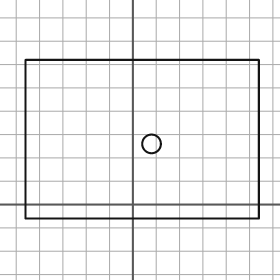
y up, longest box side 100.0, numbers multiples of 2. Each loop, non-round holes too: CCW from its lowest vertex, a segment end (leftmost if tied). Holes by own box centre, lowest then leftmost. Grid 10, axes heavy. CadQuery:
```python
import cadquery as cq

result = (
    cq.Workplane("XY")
    .moveTo(-46.0, -6.0)
    .lineTo(54.0, -6.0)
    .lineTo(54.0, 62.0)
    .lineTo(-46.0, 62.0)
    .close()
    .moveTo(8.0, 26.0)
    .circle(4.0)
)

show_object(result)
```